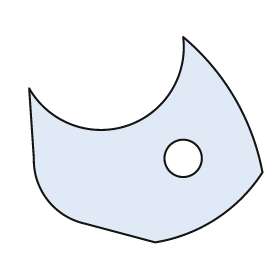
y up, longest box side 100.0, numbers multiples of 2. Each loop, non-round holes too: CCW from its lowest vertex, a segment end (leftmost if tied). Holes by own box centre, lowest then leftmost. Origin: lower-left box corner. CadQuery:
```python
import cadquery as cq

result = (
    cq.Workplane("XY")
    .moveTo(54.0, 0.0)
    .threePointArc((80.0, 10.0), (100.0, 30.0))
    .threePointArc((88.0, 62.0), (66.0, 88.0))
    .threePointArc((42.0, 50.0), (0.0, 66.0))
    .lineTo(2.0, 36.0)
    .threePointArc((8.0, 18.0), (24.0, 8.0))
    .close()
    .moveTo(66.0, 36.0)
    .circle(8.0)
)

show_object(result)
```